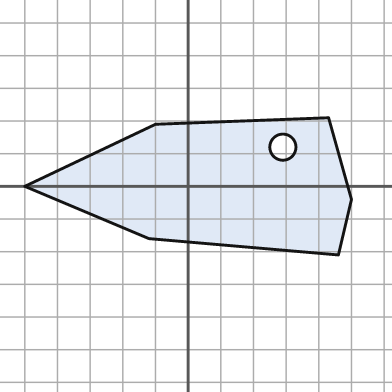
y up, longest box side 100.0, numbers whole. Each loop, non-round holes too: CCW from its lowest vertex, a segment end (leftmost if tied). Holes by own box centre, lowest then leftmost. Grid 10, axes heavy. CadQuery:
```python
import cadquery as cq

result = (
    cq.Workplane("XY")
    .moveTo(46.0, -21.0)
    .lineTo(50.0, -4.0)
    .lineTo(43.0, 21.0)
    .lineTo(-10.0, 19.0)
    .lineTo(-50.0, 0.0)
    .lineTo(-12.0, -16.0)
    .close()
    .moveTo(29.0, 12.0)
    .circle(4.0)
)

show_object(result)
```